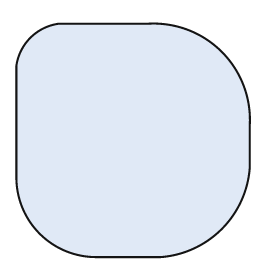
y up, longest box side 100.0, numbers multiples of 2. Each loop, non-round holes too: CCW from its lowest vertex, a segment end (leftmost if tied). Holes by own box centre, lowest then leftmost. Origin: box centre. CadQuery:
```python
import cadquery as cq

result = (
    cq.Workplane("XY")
    .moveTo(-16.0, -50.0)
    .lineTo(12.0, -50.0)
    .threePointArc((38.0, -38.0), (50.0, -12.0))
    .lineTo(50.0, 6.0)
    .threePointArc((38.0, 38.0), (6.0, 50.0))
    .lineTo(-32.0, 50.0)
    .threePointArc((-44.0, 44.0), (-50.0, 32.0))
    .lineTo(-50.0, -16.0)
    .threePointArc((-40.0, -40.0), (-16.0, -50.0))
    .close()
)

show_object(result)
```